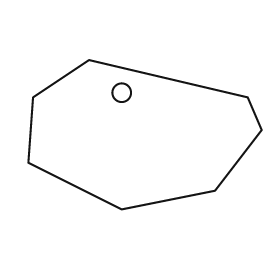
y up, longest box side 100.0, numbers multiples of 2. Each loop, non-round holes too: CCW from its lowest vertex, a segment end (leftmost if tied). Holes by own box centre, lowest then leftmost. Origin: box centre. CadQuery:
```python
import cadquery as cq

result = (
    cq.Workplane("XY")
    .moveTo(-10.0, -32.0)
    .lineTo(30.0, -24.0)
    .lineTo(50.0, 2.0)
    .lineTo(44.0, 16.0)
    .lineTo(-24.0, 32.0)
    .lineTo(-48.0, 16.0)
    .lineTo(-50.0, -12.0)
    .close()
    .moveTo(-10.0, 18.0)
    .circle(4.0)
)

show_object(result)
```